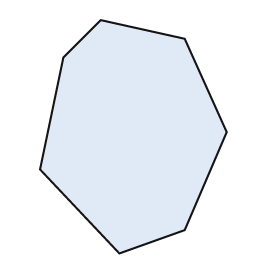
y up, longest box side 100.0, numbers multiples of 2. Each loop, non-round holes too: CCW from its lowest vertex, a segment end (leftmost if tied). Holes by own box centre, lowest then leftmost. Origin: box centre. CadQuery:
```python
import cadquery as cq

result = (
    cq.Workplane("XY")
    .moveTo(-6.0, -50.0)
    .lineTo(22.0, -40.0)
    .lineTo(40.0, 2.0)
    .lineTo(22.0, 42.0)
    .lineTo(-14.0, 50.0)
    .lineTo(-30.0, 34.0)
    .lineTo(-40.0, -14.0)
    .close()
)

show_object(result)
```